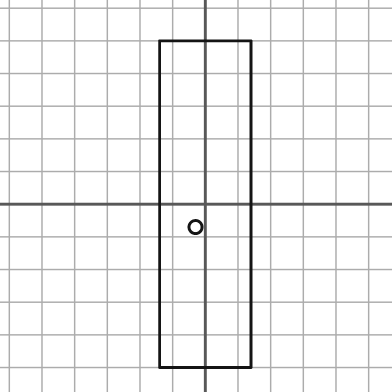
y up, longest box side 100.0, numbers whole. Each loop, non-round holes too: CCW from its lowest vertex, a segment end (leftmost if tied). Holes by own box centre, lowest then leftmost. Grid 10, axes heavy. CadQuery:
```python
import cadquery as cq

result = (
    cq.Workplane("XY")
    .moveTo(-14.0, -50.0)
    .lineTo(14.0, -50.0)
    .lineTo(14.0, 50.0)
    .lineTo(-14.0, 50.0)
    .close()
    .moveTo(-3.0, -7.0)
    .circle(2.0)
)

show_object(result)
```